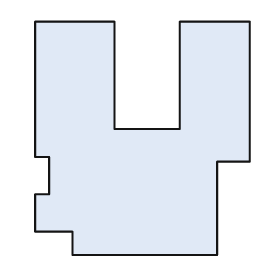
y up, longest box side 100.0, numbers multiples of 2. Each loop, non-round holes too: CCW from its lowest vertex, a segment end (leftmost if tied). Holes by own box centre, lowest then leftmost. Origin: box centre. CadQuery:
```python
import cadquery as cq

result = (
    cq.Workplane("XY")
    .moveTo(-30.0, -50.0)
    .lineTo(32.0, -50.0)
    .lineTo(32.0, -10.0)
    .lineTo(46.0, -10.0)
    .lineTo(46.0, 50.0)
    .lineTo(16.0, 50.0)
    .lineTo(16.0, 4.0)
    .lineTo(-12.0, 4.0)
    .lineTo(-12.0, 50.0)
    .lineTo(-46.0, 50.0)
    .lineTo(-46.0, -8.0)
    .lineTo(-40.0, -8.0)
    .lineTo(-40.0, -24.0)
    .lineTo(-46.0, -24.0)
    .lineTo(-46.0, -40.0)
    .lineTo(-30.0, -40.0)
    .close()
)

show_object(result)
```